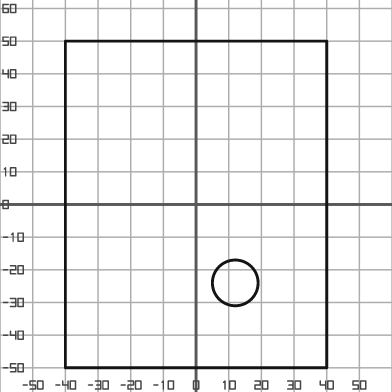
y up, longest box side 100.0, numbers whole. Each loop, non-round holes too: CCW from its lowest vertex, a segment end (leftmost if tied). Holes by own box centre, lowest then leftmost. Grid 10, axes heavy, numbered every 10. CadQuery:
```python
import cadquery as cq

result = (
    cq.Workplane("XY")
    .moveTo(-40.0, -50.0)
    .lineTo(40.0, -50.0)
    .lineTo(40.0, 50.0)
    .lineTo(-40.0, 50.0)
    .close()
    .moveTo(12.0, -24.0)
    .circle(7.0)
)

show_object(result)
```